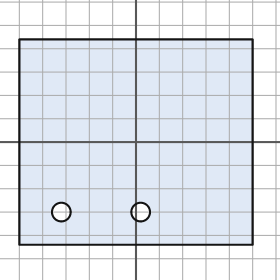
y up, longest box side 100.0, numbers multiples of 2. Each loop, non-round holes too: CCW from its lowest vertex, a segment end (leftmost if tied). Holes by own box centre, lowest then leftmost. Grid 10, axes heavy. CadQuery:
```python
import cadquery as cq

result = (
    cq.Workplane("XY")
    .moveTo(-50.0, -44.0)
    .lineTo(50.0, -44.0)
    .lineTo(50.0, 44.0)
    .lineTo(-50.0, 44.0)
    .close()
    .moveTo(-32.0, -30.0)
    .circle(4.0)
    .moveTo(2.0, -30.0)
    .circle(4.0)
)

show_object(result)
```